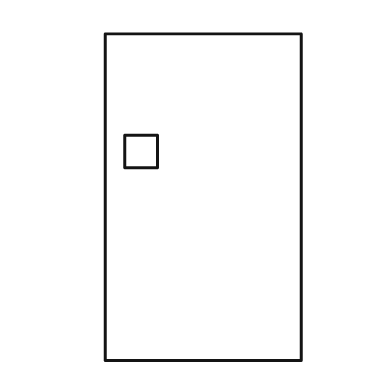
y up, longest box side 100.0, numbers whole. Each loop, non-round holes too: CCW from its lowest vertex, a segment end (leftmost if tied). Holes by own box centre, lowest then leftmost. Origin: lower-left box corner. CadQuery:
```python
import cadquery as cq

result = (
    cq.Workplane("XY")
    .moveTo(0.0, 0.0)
    .lineTo(60.0, 0.0)
    .lineTo(60.0, 100.0)
    .lineTo(0.0, 100.0)
    .close()
    .moveTo(6.0, 59.0)
    .lineTo(16.0, 59.0)
    .lineTo(16.0, 69.0)
    .lineTo(6.0, 69.0)
    .close()
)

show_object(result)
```